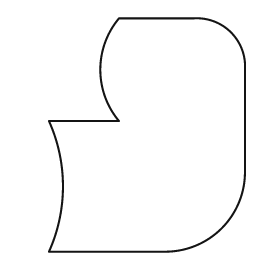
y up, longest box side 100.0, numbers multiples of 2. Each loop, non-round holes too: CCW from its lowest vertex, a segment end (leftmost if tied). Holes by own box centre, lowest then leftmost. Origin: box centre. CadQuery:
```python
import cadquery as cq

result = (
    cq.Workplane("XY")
    .moveTo(-42.0, -50.0)
    .lineTo(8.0, -50.0)
    .threePointArc((32.0, -40.0), (42.0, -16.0))
    .lineTo(42.0, 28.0)
    .threePointArc((36.0, 44.0), (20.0, 50.0))
    .lineTo(-12.0, 50.0)
    .threePointArc((-20.0, 28.0), (-12.0, 6.0))
    .lineTo(-42.0, 6.0)
    .threePointArc((-36.0, -22.0), (-42.0, -50.0))
    .close()
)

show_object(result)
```